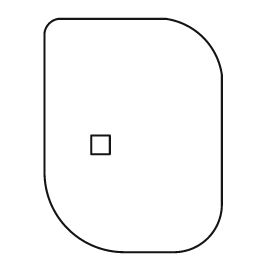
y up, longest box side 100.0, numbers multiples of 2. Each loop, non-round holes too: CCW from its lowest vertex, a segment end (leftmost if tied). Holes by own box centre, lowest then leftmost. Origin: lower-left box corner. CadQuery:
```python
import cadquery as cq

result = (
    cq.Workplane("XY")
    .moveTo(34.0, 0.0)
    .lineTo(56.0, 0.0)
    .threePointArc((70.0, 6.0), (76.0, 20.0))
    .lineTo(76.0, 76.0)
    .threePointArc((68.0, 92.0), (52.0, 100.0))
    .lineTo(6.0, 100.0)
    .threePointArc((2.0, 98.0), (0.0, 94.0))
    .lineTo(0.0, 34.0)
    .threePointArc((10.0, 10.0), (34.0, 0.0))
    .close()
    .moveTo(20.0, 42.0)
    .lineTo(28.0, 42.0)
    .lineTo(28.0, 50.0)
    .lineTo(20.0, 50.0)
    .close()
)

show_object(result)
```